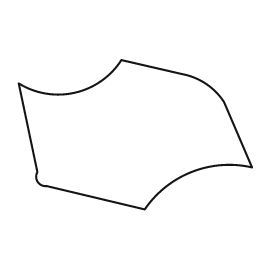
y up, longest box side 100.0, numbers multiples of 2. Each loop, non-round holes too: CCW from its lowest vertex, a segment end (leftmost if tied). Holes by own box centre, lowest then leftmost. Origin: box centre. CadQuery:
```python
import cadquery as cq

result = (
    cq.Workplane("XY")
    .moveTo(4.0, -32.0)
    .threePointArc((24.0, -16.0), (50.0, -14.0))
    .lineTo(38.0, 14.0)
    .threePointArc((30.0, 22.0), (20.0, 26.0))
    .lineTo(-6.0, 32.0)
    .threePointArc((-26.0, 18.0), (-50.0, 22.0))
    .lineTo(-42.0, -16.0)
    .threePointArc((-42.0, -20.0), (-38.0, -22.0))
    .close()
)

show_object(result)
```